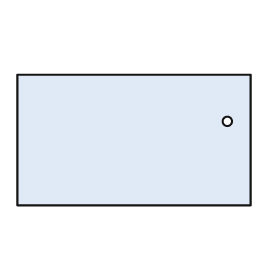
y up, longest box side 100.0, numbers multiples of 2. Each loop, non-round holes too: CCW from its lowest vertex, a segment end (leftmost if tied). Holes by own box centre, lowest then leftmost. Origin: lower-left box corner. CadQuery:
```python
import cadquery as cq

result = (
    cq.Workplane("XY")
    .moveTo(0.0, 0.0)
    .lineTo(100.0, 0.0)
    .lineTo(100.0, 56.0)
    .lineTo(0.0, 56.0)
    .close()
    .moveTo(90.0, 36.0)
    .circle(2.0)
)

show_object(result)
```